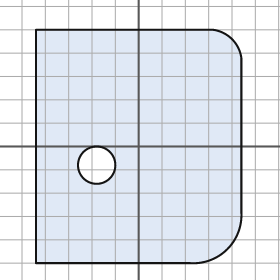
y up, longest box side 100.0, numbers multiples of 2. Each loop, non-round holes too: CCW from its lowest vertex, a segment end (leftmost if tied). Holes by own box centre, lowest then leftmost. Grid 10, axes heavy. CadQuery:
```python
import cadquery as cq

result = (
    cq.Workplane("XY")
    .moveTo(-44.0, -50.0)
    .lineTo(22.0, -50.0)
    .threePointArc((38.0, -44.0), (44.0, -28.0))
    .lineTo(44.0, 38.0)
    .threePointArc((40.0, 46.0), (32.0, 50.0))
    .lineTo(-44.0, 50.0)
    .close()
    .moveTo(-18.0, -8.0)
    .circle(8.0)
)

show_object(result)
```